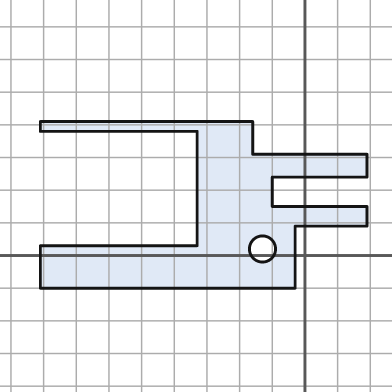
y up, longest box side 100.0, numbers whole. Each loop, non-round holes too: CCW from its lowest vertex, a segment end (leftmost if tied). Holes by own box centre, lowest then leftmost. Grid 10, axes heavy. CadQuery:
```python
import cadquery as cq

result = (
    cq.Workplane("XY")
    .moveTo(-81.0, -10.0)
    .lineTo(-3.0, -10.0)
    .lineTo(-3.0, 9.0)
    .lineTo(19.0, 9.0)
    .lineTo(19.0, 15.0)
    .lineTo(-10.0, 15.0)
    .lineTo(-10.0, 24.0)
    .lineTo(19.0, 24.0)
    .lineTo(19.0, 31.0)
    .lineTo(-16.0, 31.0)
    .lineTo(-16.0, 41.0)
    .lineTo(-81.0, 41.0)
    .lineTo(-81.0, 38.0)
    .lineTo(-33.0, 38.0)
    .lineTo(-33.0, 3.0)
    .lineTo(-81.0, 3.0)
    .close()
    .moveTo(-13.0, 2.0)
    .circle(4.0)
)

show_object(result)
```